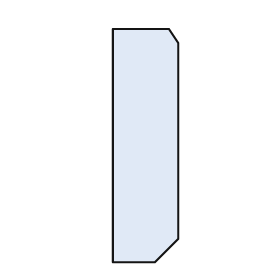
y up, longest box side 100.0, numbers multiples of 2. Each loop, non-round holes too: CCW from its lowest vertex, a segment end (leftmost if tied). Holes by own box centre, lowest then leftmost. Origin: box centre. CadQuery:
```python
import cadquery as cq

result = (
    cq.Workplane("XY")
    .moveTo(-14.0, -50.0)
    .lineTo(4.0, -50.0)
    .lineTo(14.0, -40.0)
    .lineTo(14.0, 44.0)
    .lineTo(10.0, 50.0)
    .lineTo(-14.0, 50.0)
    .close()
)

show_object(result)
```